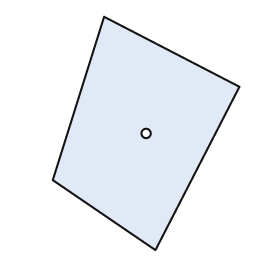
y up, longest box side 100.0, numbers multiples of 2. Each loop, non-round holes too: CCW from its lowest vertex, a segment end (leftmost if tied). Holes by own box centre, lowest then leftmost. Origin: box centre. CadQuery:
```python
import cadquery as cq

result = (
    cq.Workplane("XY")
    .moveTo(4.0, -50.0)
    .lineTo(40.0, 20.0)
    .lineTo(-18.0, 50.0)
    .lineTo(-40.0, -20.0)
    .close()
    .moveTo(0.0, 0.0)
    .circle(2.0)
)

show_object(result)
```